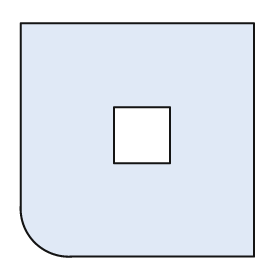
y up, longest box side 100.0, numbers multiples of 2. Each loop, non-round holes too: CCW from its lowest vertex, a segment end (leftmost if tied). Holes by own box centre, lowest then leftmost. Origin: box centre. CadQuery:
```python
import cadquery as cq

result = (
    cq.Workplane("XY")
    .moveTo(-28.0, -50.0)
    .lineTo(50.0, -50.0)
    .lineTo(50.0, 50.0)
    .lineTo(-50.0, 50.0)
    .lineTo(-50.0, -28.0)
    .threePointArc((-44.0, -44.0), (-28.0, -50.0))
    .close()
    .moveTo(-10.0, -10.0)
    .lineTo(14.0, -10.0)
    .lineTo(14.0, 14.0)
    .lineTo(-10.0, 14.0)
    .close()
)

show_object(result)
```